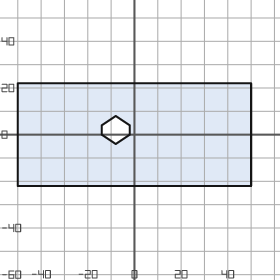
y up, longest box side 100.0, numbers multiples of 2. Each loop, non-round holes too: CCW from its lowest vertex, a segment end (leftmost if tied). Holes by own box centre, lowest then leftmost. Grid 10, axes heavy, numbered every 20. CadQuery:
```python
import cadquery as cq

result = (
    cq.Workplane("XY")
    .moveTo(-50.0, -22.0)
    .lineTo(50.0, -22.0)
    .lineTo(50.0, 22.0)
    .lineTo(-50.0, 22.0)
    .close()
    .moveTo(-8.0, -4.0)
    .lineTo(-2.0, 0.0)
    .lineTo(-2.0, 4.0)
    .lineTo(-8.0, 8.0)
    .lineTo(-14.0, 4.0)
    .lineTo(-14.0, 0.0)
    .close()
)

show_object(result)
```